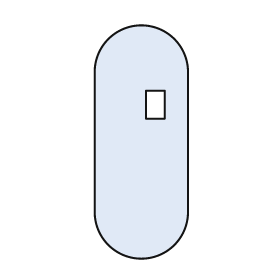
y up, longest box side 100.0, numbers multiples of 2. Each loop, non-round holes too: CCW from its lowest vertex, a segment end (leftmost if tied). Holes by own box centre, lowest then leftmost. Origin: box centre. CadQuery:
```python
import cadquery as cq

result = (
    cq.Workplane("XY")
    .moveTo(-20.0, -30.0)
    .threePointArc((0.0, -50.0), (20.0, -30.0))
    .lineTo(20.0, 30.0)
    .threePointArc((0.0, 50.0), (-20.0, 30.0))
    .close()
    .moveTo(2.0, 10.0)
    .lineTo(10.0, 10.0)
    .lineTo(10.0, 22.0)
    .lineTo(2.0, 22.0)
    .close()
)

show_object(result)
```